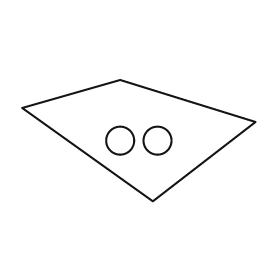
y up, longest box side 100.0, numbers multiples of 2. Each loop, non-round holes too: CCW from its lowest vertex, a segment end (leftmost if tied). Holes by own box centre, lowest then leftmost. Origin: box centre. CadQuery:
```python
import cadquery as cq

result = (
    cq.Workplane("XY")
    .moveTo(6.0, -26.0)
    .lineTo(50.0, 8.0)
    .lineTo(-8.0, 26.0)
    .lineTo(-50.0, 14.0)
    .close()
    .moveTo(-8.0, 0.0)
    .circle(6.0)
    .moveTo(8.0, 0.0)
    .circle(6.0)
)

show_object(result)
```